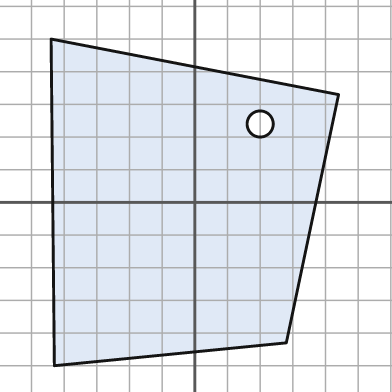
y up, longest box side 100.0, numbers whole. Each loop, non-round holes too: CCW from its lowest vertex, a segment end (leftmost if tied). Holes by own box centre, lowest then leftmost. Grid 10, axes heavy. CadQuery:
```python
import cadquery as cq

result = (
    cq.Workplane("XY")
    .moveTo(-43.0, -50.0)
    .lineTo(28.0, -43.0)
    .lineTo(44.0, 33.0)
    .lineTo(-44.0, 50.0)
    .close()
    .moveTo(20.0, 24.0)
    .circle(4.0)
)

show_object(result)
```